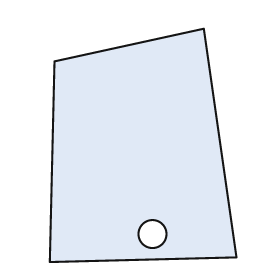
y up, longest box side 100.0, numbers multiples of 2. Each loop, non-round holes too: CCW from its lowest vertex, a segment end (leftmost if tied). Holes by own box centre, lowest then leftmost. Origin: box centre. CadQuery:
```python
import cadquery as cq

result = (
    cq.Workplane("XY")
    .moveTo(-40.0, -50.0)
    .lineTo(40.0, -48.0)
    .lineTo(26.0, 50.0)
    .lineTo(-38.0, 36.0)
    .close()
    .moveTo(4.0, -38.0)
    .circle(6.0)
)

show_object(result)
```